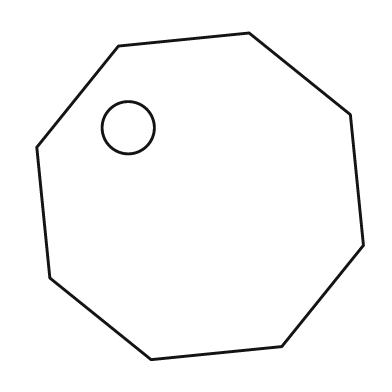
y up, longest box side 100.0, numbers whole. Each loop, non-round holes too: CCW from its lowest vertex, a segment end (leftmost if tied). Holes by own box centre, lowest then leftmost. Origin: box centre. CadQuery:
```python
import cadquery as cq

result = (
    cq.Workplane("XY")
    .moveTo(-15.0, -50.0)
    .lineTo(25.0, -46.0)
    .lineTo(50.0, -15.0)
    .lineTo(46.0, 25.0)
    .lineTo(15.0, 50.0)
    .lineTo(-25.0, 46.0)
    .lineTo(-50.0, 15.0)
    .lineTo(-46.0, -25.0)
    .close()
    .moveTo(-22.0, 21.0)
    .circle(8.0)
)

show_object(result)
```